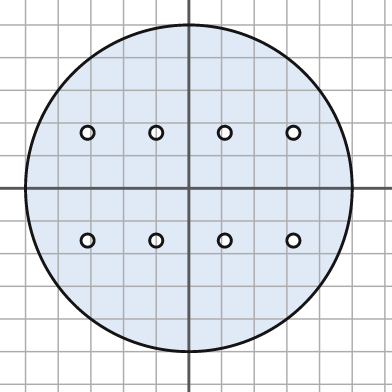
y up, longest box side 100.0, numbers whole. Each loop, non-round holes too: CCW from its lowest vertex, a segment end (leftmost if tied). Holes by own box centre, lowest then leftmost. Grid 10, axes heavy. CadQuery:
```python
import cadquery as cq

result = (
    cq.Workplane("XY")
    .moveTo(0.0, 0.0)
    .circle(50.0)
    .moveTo(-31.0, -16.0)
    .circle(2.0)
    .moveTo(-10.0, -16.0)
    .circle(2.0)
    .moveTo(11.0, -16.0)
    .circle(2.0)
    .moveTo(32.0, -16.0)
    .circle(2.0)
    .moveTo(-31.0, 17.0)
    .circle(2.0)
    .moveTo(-10.0, 17.0)
    .circle(2.0)
    .moveTo(11.0, 17.0)
    .circle(2.0)
    .moveTo(32.0, 17.0)
    .circle(2.0)
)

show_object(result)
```